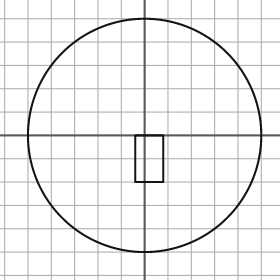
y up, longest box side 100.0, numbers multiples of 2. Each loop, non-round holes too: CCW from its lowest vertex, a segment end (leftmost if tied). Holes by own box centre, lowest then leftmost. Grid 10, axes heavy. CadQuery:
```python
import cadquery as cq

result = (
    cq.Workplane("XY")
    .moveTo(0.0, 0.0)
    .circle(50.0)
    .moveTo(-4.0, -20.0)
    .lineTo(8.0, -20.0)
    .lineTo(8.0, 0.0)
    .lineTo(-4.0, 0.0)
    .close()
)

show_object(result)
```